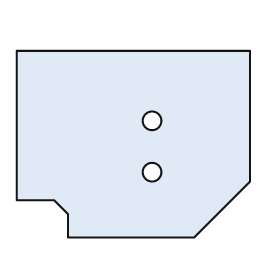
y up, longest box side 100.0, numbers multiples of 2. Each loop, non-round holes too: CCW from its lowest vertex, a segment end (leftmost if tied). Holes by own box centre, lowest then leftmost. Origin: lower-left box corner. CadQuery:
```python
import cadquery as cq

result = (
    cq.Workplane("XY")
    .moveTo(22.0, 0.0)
    .lineTo(76.0, 0.0)
    .lineTo(100.0, 24.0)
    .lineTo(100.0, 80.0)
    .lineTo(0.0, 80.0)
    .lineTo(0.0, 16.0)
    .lineTo(16.0, 16.0)
    .lineTo(22.0, 10.0)
    .close()
    .moveTo(58.0, 28.0)
    .circle(4.0)
    .moveTo(58.0, 50.0)
    .circle(4.0)
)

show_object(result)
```